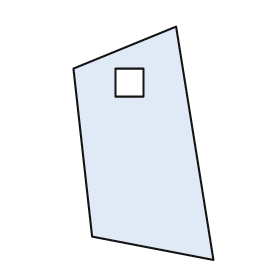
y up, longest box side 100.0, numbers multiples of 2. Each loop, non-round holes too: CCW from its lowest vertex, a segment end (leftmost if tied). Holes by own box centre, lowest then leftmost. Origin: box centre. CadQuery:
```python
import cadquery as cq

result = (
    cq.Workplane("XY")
    .moveTo(30.0, -50.0)
    .lineTo(14.0, 50.0)
    .lineTo(-30.0, 32.0)
    .lineTo(-22.0, -40.0)
    .close()
    .moveTo(-12.0, 20.0)
    .lineTo(0.0, 20.0)
    .lineTo(0.0, 32.0)
    .lineTo(-12.0, 32.0)
    .close()
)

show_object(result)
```